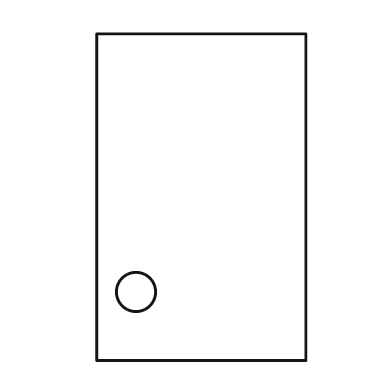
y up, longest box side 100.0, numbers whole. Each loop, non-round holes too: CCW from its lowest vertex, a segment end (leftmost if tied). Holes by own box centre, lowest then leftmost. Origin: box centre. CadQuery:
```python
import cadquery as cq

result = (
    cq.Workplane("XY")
    .moveTo(-32.0, -50.0)
    .lineTo(32.0, -50.0)
    .lineTo(32.0, 50.0)
    .lineTo(-32.0, 50.0)
    .close()
    .moveTo(-20.0, -29.0)
    .circle(6.0)
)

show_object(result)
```